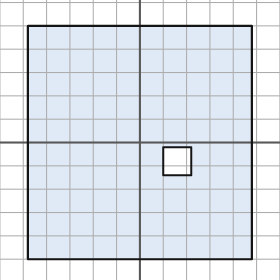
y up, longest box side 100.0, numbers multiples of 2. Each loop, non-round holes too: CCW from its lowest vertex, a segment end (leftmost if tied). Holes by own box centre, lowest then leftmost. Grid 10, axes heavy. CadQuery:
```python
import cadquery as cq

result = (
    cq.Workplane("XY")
    .moveTo(-48.0, -50.0)
    .lineTo(48.0, -50.0)
    .lineTo(48.0, 50.0)
    .lineTo(-48.0, 50.0)
    .close()
    .moveTo(10.0, -14.0)
    .lineTo(22.0, -14.0)
    .lineTo(22.0, -2.0)
    .lineTo(10.0, -2.0)
    .close()
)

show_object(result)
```